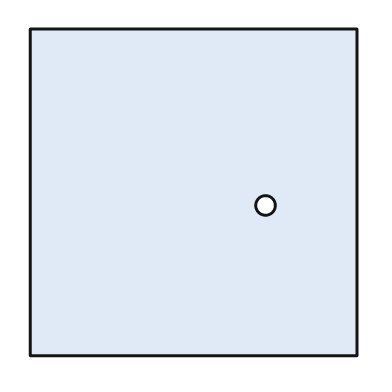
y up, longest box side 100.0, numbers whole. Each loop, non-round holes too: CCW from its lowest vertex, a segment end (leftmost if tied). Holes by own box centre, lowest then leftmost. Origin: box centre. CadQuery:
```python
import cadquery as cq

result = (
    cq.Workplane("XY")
    .moveTo(-50.0, -50.0)
    .lineTo(50.0, -50.0)
    .lineTo(50.0, 50.0)
    .lineTo(-50.0, 50.0)
    .close()
    .moveTo(22.0, -4.0)
    .circle(3.0)
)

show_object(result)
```